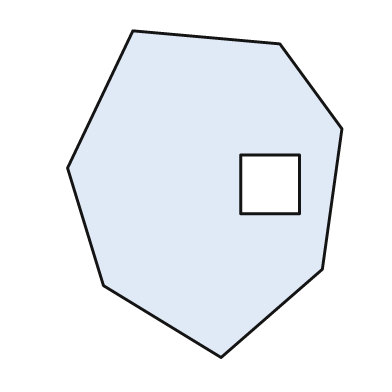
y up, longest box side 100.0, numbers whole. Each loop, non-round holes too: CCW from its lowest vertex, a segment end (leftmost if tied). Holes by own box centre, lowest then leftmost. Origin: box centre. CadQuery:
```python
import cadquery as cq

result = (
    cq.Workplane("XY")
    .moveTo(5.0, -50.0)
    .lineTo(36.0, -23.0)
    .lineTo(42.0, 20.0)
    .lineTo(23.0, 46.0)
    .lineTo(-22.0, 50.0)
    .lineTo(-42.0, 8.0)
    .lineTo(-31.0, -28.0)
    .close()
    .moveTo(11.0, -6.0)
    .lineTo(29.0, -6.0)
    .lineTo(29.0, 12.0)
    .lineTo(11.0, 12.0)
    .close()
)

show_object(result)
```